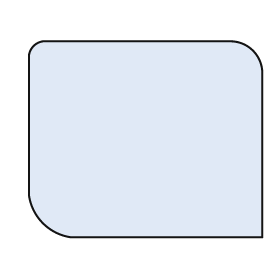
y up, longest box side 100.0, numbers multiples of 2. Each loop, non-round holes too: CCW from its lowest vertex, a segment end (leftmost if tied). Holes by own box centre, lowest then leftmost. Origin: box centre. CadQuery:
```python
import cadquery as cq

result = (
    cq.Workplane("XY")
    .moveTo(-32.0, -42.0)
    .lineTo(50.0, -42.0)
    .lineTo(50.0, 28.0)
    .threePointArc((46.0, 38.0), (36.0, 42.0))
    .lineTo(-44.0, 42.0)
    .threePointArc((-48.0, 40.0), (-50.0, 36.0))
    .lineTo(-50.0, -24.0)
    .threePointArc((-44.0, -36.0), (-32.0, -42.0))
    .close()
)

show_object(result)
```